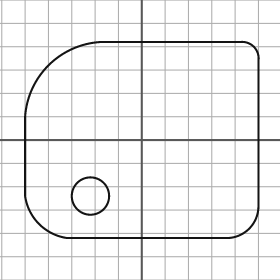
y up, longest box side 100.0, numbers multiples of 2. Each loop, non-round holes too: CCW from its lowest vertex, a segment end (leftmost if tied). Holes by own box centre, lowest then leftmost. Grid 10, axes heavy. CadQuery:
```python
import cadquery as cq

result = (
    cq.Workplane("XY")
    .moveTo(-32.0, -42.0)
    .lineTo(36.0, -42.0)
    .threePointArc((46.0, -38.0), (50.0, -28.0))
    .lineTo(50.0, 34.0)
    .threePointArc((48.0, 40.0), (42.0, 42.0))
    .lineTo(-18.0, 42.0)
    .threePointArc((-40.0, 32.0), (-50.0, 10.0))
    .lineTo(-50.0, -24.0)
    .threePointArc((-44.0, -36.0), (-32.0, -42.0))
    .close()
    .moveTo(-22.0, -24.0)
    .circle(8.0)
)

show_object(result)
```